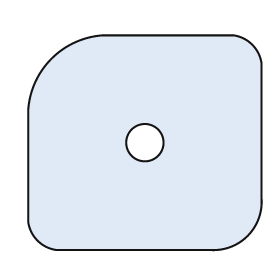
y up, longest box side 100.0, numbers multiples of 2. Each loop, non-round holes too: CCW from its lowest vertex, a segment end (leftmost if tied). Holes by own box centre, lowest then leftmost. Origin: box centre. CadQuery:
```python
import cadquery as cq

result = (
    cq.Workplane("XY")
    .moveTo(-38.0, -46.0)
    .lineTo(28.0, -46.0)
    .threePointArc((44.0, -40.0), (50.0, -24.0))
    .lineTo(50.0, 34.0)
    .threePointArc((46.0, 42.0), (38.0, 46.0))
    .lineTo(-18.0, 46.0)
    .threePointArc((-40.0, 36.0), (-50.0, 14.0))
    .lineTo(-50.0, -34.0)
    .threePointArc((-46.0, -42.0), (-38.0, -46.0))
    .close()
    .moveTo(0.0, 0.0)
    .circle(8.0)
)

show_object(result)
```